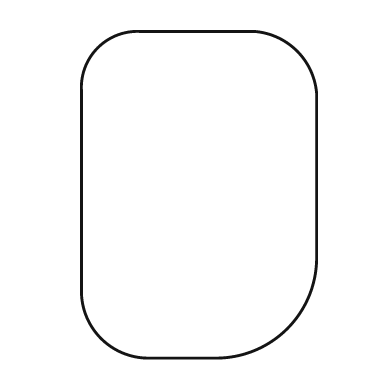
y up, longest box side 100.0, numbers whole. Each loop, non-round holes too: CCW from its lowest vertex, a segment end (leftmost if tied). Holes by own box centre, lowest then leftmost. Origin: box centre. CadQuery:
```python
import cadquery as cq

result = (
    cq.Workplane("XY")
    .moveTo(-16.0, -50.0)
    .lineTo(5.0, -50.0)
    .threePointArc((27.0, -41.0), (36.0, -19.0))
    .lineTo(36.0, 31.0)
    .threePointArc((30.0, 44.0), (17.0, 50.0))
    .lineTo(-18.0, 50.0)
    .threePointArc((-31.0, 45.0), (-36.0, 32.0))
    .lineTo(-36.0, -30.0)
    .threePointArc((-30.0, -44.0), (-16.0, -50.0))
    .close()
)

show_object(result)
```